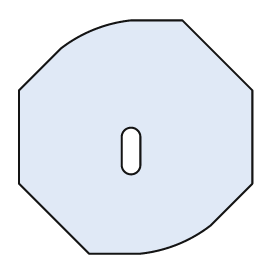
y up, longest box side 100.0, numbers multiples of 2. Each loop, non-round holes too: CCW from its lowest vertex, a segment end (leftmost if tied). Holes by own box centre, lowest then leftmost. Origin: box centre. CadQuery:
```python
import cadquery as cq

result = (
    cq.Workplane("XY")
    .moveTo(-20.0, -50.0)
    .lineTo(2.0, -50.0)
    .threePointArc((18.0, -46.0), (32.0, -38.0))
    .lineTo(50.0, -20.0)
    .lineTo(50.0, 20.0)
    .lineTo(20.0, 50.0)
    .lineTo(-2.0, 50.0)
    .threePointArc((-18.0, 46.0), (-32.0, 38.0))
    .lineTo(-50.0, 20.0)
    .lineTo(-50.0, -20.0)
    .close()
    .moveTo(-6.0, -12.0)
    .threePointArc((-2.0, -16.0), (2.0, -12.0))
    .lineTo(2.0, 0.0)
    .threePointArc((-2.0, 4.0), (-6.0, 0.0))
    .close()
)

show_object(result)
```